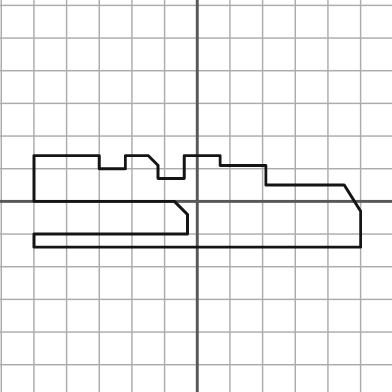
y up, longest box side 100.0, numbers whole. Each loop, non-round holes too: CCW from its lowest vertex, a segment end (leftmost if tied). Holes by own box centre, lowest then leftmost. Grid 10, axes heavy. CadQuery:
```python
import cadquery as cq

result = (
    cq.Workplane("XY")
    .moveTo(-50.0, -14.0)
    .lineTo(50.0, -14.0)
    .lineTo(50.0, -3.0)
    .lineTo(45.0, 5.0)
    .lineTo(21.0, 5.0)
    .lineTo(21.0, 11.0)
    .lineTo(7.0, 11.0)
    .lineTo(7.0, 14.0)
    .lineTo(-4.0, 14.0)
    .lineTo(-4.0, 7.0)
    .lineTo(-12.0, 7.0)
    .lineTo(-12.0, 11.0)
    .lineTo(-15.0, 14.0)
    .lineTo(-22.0, 14.0)
    .lineTo(-22.0, 10.0)
    .lineTo(-30.0, 10.0)
    .lineTo(-30.0, 14.0)
    .lineTo(-50.0, 14.0)
    .lineTo(-50.0, 0.0)
    .lineTo(-7.0, 0.0)
    .lineTo(-3.0, -4.0)
    .lineTo(-3.0, -10.0)
    .lineTo(-50.0, -10.0)
    .close()
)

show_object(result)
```